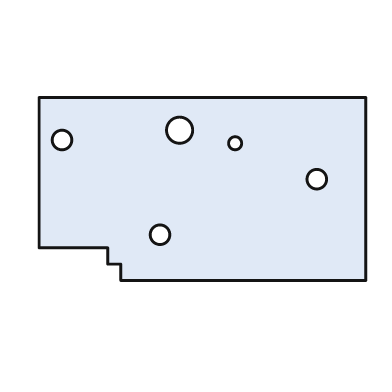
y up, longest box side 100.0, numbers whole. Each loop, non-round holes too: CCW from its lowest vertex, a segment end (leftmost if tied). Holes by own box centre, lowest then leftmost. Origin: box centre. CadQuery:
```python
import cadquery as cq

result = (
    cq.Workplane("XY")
    .moveTo(-25.0, -28.0)
    .lineTo(50.0, -28.0)
    .lineTo(50.0, 28.0)
    .lineTo(-50.0, 28.0)
    .lineTo(-50.0, -18.0)
    .lineTo(-29.0, -18.0)
    .lineTo(-29.0, -23.0)
    .lineTo(-25.0, -23.0)
    .close()
    .moveTo(-13.0, -14.0)
    .circle(3.0)
    .moveTo(35.0, 3.0)
    .circle(3.0)
    .moveTo(10.0, 14.0)
    .circle(2.0)
    .moveTo(-43.0, 15.0)
    .circle(3.0)
    .moveTo(-7.0, 18.0)
    .circle(4.0)
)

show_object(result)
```